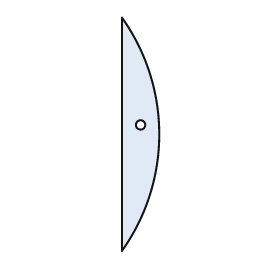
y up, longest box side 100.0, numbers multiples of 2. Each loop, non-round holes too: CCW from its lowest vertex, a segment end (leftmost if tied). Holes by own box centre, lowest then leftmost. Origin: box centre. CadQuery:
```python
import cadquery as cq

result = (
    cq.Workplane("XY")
    .moveTo(-8.0, -50.0)
    .threePointArc((8.0, 0.0), (-8.0, 50.0))
    .close()
    .moveTo(0.0, 4.0)
    .circle(2.0)
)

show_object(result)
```